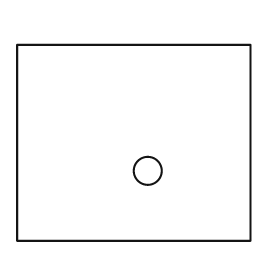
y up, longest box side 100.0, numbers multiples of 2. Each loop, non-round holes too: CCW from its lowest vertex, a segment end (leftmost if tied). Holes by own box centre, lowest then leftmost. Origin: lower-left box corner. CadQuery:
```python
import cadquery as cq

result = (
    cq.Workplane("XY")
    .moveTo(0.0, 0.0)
    .lineTo(100.0, 0.0)
    .lineTo(100.0, 84.0)
    .lineTo(0.0, 84.0)
    .close()
    .moveTo(56.0, 30.0)
    .circle(6.0)
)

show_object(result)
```